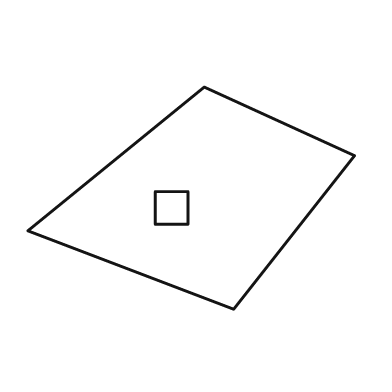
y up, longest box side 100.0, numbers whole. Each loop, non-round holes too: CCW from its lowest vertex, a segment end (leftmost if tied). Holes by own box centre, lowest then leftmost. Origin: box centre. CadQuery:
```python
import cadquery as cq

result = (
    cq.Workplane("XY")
    .moveTo(13.0, -34.0)
    .lineTo(50.0, 13.0)
    .lineTo(4.0, 34.0)
    .lineTo(-50.0, -10.0)
    .close()
    .moveTo(-11.0, -8.0)
    .lineTo(-1.0, -8.0)
    .lineTo(-1.0, 2.0)
    .lineTo(-11.0, 2.0)
    .close()
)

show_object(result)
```